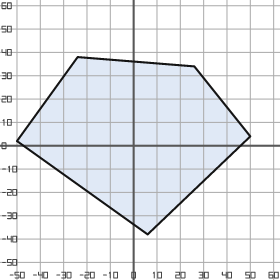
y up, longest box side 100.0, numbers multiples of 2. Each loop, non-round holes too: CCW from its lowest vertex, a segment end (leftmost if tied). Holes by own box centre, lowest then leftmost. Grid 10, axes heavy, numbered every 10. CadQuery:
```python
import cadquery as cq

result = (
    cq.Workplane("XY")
    .moveTo(6.0, -38.0)
    .lineTo(50.0, 4.0)
    .lineTo(26.0, 34.0)
    .lineTo(-24.0, 38.0)
    .lineTo(-50.0, 2.0)
    .close()
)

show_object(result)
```